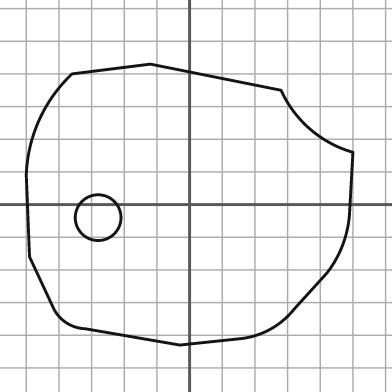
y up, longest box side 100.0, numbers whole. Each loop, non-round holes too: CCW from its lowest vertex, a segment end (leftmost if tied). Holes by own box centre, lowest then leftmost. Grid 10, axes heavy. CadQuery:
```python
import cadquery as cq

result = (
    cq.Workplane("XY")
    .moveTo(-3.0, -43.0)
    .lineTo(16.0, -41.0)
    .threePointArc((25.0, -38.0), (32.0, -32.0))
    .lineTo(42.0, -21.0)
    .threePointArc((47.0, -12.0), (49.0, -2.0))
    .lineTo(50.0, 16.0)
    .threePointArc((37.0, 23.0), (28.0, 35.0))
    .lineTo(-12.0, 43.0)
    .lineTo(-36.0, 40.0)
    .threePointArc((-46.0, 26.0), (-50.0, 9.0))
    .lineTo(-49.0, -16.0)
    .lineTo(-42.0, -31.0)
    .threePointArc((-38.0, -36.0), (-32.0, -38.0))
    .close()
    .moveTo(-28.0, -4.0)
    .circle(7.0)
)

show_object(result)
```